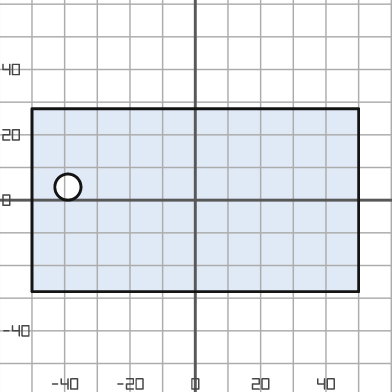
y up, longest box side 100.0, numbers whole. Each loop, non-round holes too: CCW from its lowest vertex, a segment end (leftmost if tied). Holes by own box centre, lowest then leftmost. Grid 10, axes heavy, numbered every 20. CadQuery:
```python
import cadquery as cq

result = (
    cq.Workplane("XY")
    .moveTo(-50.0, -28.0)
    .lineTo(50.0, -28.0)
    .lineTo(50.0, 28.0)
    .lineTo(-50.0, 28.0)
    .close()
    .moveTo(-39.0, 4.0)
    .circle(4.0)
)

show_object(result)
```